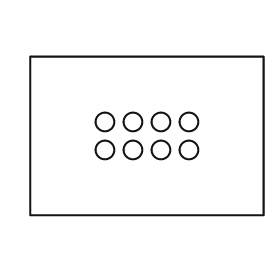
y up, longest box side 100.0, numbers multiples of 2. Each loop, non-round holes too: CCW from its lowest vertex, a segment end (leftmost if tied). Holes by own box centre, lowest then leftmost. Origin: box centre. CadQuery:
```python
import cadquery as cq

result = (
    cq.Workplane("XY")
    .moveTo(-50.0, -34.0)
    .lineTo(50.0, -34.0)
    .lineTo(50.0, 34.0)
    .lineTo(-50.0, 34.0)
    .close()
    .moveTo(-18.0, -6.0)
    .circle(4.0)
    .moveTo(-6.0, -6.0)
    .circle(4.0)
    .moveTo(6.0, -6.0)
    .circle(4.0)
    .moveTo(18.0, -6.0)
    .circle(4.0)
    .moveTo(-18.0, 6.0)
    .circle(4.0)
    .moveTo(-6.0, 6.0)
    .circle(4.0)
    .moveTo(6.0, 6.0)
    .circle(4.0)
    .moveTo(18.0, 6.0)
    .circle(4.0)
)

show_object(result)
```